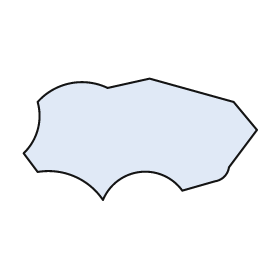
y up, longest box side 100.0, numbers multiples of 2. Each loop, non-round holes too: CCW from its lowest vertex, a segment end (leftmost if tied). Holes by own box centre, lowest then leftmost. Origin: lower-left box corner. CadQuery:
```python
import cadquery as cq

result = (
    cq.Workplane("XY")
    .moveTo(34.0, 0.0)
    .threePointArc((50.0, 12.0), (68.0, 4.0))
    .lineTo(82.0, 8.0)
    .threePointArc((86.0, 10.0), (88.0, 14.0))
    .lineTo(100.0, 30.0)
    .lineTo(90.0, 42.0)
    .lineTo(54.0, 52.0)
    .lineTo(36.0, 48.0)
    .threePointArc((20.0, 50.0), (6.0, 42.0))
    .threePointArc((6.0, 30.0), (0.0, 20.0))
    .lineTo(6.0, 12.0)
    .threePointArc((22.0, 10.0), (34.0, 0.0))
    .close()
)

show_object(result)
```